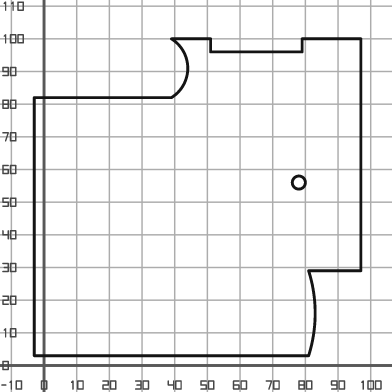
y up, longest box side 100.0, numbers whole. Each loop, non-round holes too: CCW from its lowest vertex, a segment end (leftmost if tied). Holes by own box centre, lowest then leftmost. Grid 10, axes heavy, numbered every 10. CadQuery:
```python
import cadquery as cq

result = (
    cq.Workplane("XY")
    .moveTo(-3.0, 3.0)
    .lineTo(81.0, 3.0)
    .threePointArc((83.0, 16.0), (81.0, 29.0))
    .lineTo(97.0, 29.0)
    .lineTo(97.0, 100.0)
    .lineTo(79.0, 100.0)
    .lineTo(79.0, 96.0)
    .lineTo(51.0, 96.0)
    .lineTo(51.0, 100.0)
    .lineTo(39.0, 100.0)
    .threePointArc((44.0, 91.0), (39.0, 82.0))
    .lineTo(-3.0, 82.0)
    .close()
    .moveTo(78.0, 56.0)
    .circle(2.0)
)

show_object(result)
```